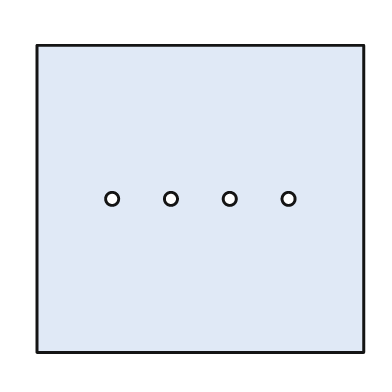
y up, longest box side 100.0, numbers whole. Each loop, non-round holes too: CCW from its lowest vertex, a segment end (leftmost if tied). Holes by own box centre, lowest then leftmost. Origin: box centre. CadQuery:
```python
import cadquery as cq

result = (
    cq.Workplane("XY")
    .moveTo(-50.0, -47.0)
    .lineTo(50.0, -47.0)
    .lineTo(50.0, 47.0)
    .lineTo(-50.0, 47.0)
    .close()
    .moveTo(-27.0, 0.0)
    .circle(2.0)
    .moveTo(-9.0, 0.0)
    .circle(2.0)
    .moveTo(9.0, 0.0)
    .circle(2.0)
    .moveTo(27.0, 0.0)
    .circle(2.0)
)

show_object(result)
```